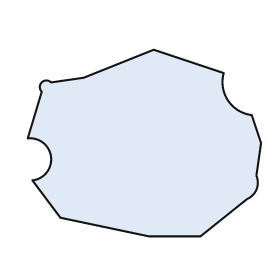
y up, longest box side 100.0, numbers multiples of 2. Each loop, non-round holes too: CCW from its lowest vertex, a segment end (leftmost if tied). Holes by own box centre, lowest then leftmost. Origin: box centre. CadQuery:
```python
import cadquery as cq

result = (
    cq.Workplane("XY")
    .moveTo(2.0, -40.0)
    .lineTo(24.0, -40.0)
    .lineTo(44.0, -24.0)
    .threePointArc((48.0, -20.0), (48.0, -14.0))
    .lineTo(50.0, 0.0)
    .lineTo(46.0, 12.0)
    .threePointArc((36.0, 18.0), (34.0, 30.0))
    .lineTo(4.0, 40.0)
    .lineTo(-26.0, 28.0)
    .lineTo(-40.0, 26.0)
    .threePointArc((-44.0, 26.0), (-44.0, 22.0))
    .lineTo(-50.0, 2.0)
    .threePointArc((-40.0, -6.0), (-48.0, -16.0))
    .lineTo(-36.0, -32.0)
    .close()
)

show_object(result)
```